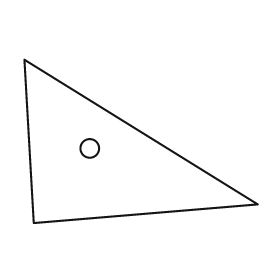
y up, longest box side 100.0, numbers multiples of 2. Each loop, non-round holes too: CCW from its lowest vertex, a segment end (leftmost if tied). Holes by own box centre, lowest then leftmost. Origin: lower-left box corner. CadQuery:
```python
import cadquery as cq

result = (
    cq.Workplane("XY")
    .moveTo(4.0, 0.0)
    .lineTo(100.0, 8.0)
    .lineTo(0.0, 70.0)
    .close()
    .moveTo(28.0, 32.0)
    .circle(4.0)
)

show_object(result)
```